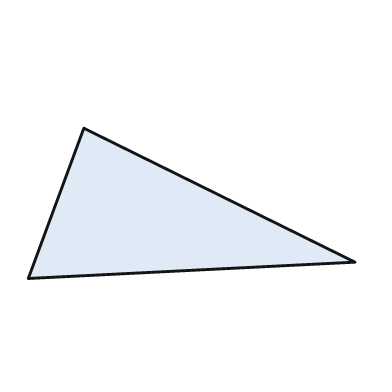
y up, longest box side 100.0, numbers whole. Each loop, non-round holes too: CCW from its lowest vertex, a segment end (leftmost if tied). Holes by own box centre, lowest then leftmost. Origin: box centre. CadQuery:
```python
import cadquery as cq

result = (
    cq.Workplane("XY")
    .moveTo(-50.0, -23.0)
    .lineTo(50.0, -18.0)
    .lineTo(-33.0, 23.0)
    .close()
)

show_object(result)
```